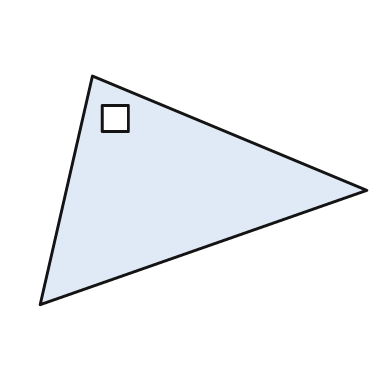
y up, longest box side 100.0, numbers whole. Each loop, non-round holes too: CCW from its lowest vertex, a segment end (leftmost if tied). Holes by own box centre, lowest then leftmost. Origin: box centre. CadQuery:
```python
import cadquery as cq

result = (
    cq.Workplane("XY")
    .moveTo(-50.0, -35.0)
    .lineTo(50.0, 0.0)
    .lineTo(-34.0, 35.0)
    .close()
    .moveTo(-31.0, 18.0)
    .lineTo(-23.0, 18.0)
    .lineTo(-23.0, 26.0)
    .lineTo(-31.0, 26.0)
    .close()
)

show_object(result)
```